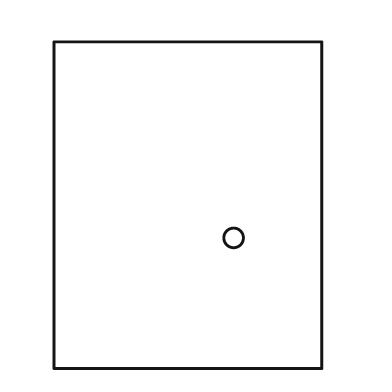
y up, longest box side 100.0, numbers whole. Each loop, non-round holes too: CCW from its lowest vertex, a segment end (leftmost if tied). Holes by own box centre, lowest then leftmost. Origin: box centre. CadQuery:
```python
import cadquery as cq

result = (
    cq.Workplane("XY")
    .moveTo(-41.0, -50.0)
    .lineTo(41.0, -50.0)
    .lineTo(41.0, 50.0)
    .lineTo(-41.0, 50.0)
    .close()
    .moveTo(14.0, -10.0)
    .circle(3.0)
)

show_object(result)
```